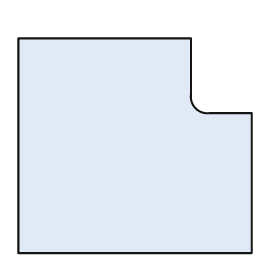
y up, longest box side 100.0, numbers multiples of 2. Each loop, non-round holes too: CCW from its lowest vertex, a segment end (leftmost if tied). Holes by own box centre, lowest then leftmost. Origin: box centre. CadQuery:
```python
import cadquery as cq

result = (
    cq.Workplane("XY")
    .moveTo(-50.0, -46.0)
    .lineTo(50.0, -46.0)
    .lineTo(50.0, 14.0)
    .lineTo(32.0, 14.0)
    .threePointArc((26.0, 16.0), (24.0, 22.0))
    .lineTo(24.0, 46.0)
    .lineTo(-50.0, 46.0)
    .close()
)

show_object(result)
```